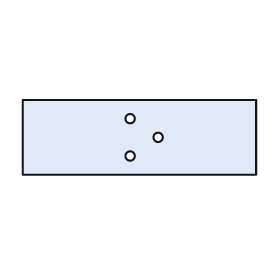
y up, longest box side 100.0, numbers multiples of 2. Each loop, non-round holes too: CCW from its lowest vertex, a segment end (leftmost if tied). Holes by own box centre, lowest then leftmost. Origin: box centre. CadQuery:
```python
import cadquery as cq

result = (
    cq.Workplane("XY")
    .moveTo(-50.0, -16.0)
    .lineTo(50.0, -16.0)
    .lineTo(50.0, 16.0)
    .lineTo(-50.0, 16.0)
    .close()
    .moveTo(-4.0, -8.0)
    .circle(2.0)
    .moveTo(8.0, 0.0)
    .circle(2.0)
    .moveTo(-4.0, 8.0)
    .circle(2.0)
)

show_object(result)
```